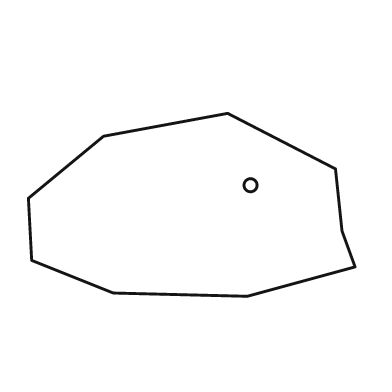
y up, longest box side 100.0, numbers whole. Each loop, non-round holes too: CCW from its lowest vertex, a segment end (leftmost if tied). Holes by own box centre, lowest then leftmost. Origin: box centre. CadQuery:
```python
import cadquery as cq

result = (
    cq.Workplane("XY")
    .moveTo(17.0, -28.0)
    .lineTo(50.0, -19.0)
    .lineTo(46.0, -8.0)
    .lineTo(44.0, 11.0)
    .lineTo(11.0, 28.0)
    .lineTo(-27.0, 21.0)
    .lineTo(-50.0, 2.0)
    .lineTo(-49.0, -17.0)
    .lineTo(-24.0, -27.0)
    .close()
    .moveTo(18.0, 6.0)
    .circle(2.0)
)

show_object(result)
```